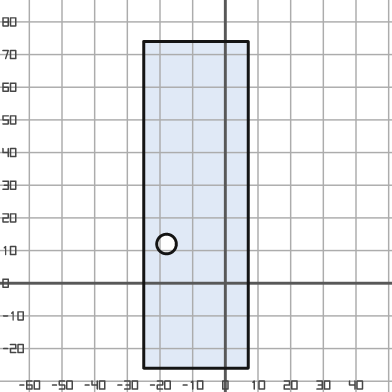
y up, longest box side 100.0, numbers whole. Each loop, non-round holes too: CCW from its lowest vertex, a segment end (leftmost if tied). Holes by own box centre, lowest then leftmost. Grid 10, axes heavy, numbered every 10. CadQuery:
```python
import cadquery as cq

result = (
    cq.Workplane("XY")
    .moveTo(-25.0, -26.0)
    .lineTo(7.0, -26.0)
    .lineTo(7.0, 74.0)
    .lineTo(-25.0, 74.0)
    .close()
    .moveTo(-18.0, 12.0)
    .circle(3.0)
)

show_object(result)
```